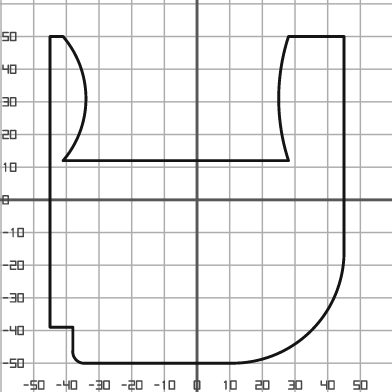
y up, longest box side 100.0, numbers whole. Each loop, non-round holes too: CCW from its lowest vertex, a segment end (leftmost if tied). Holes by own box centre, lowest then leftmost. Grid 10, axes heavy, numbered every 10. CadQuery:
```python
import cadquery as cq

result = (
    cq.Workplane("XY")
    .moveTo(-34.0, -50.0)
    .lineTo(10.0, -50.0)
    .threePointArc((35.0, -40.0), (45.0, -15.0))
    .lineTo(45.0, 50.0)
    .lineTo(28.0, 50.0)
    .threePointArc((25.0, 31.0), (28.0, 12.0))
    .lineTo(-41.0, 12.0)
    .threePointArc((-34.0, 31.0), (-41.0, 50.0))
    .lineTo(-45.0, 50.0)
    .lineTo(-45.0, -39.0)
    .lineTo(-38.0, -39.0)
    .lineTo(-38.0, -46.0)
    .threePointArc((-37.0, -49.0), (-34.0, -50.0))
    .close()
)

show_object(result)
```